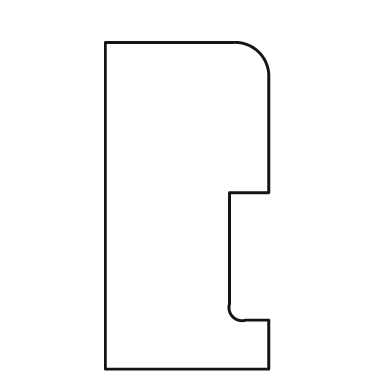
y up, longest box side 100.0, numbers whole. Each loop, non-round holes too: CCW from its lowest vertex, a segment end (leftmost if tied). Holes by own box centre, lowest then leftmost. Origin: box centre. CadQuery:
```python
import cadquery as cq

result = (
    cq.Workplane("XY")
    .moveTo(-25.0, -50.0)
    .lineTo(25.0, -50.0)
    .lineTo(25.0, -35.0)
    .lineTo(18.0, -35.0)
    .threePointArc((14.0, -34.0), (13.0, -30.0))
    .lineTo(13.0, 4.0)
    .lineTo(25.0, 4.0)
    .lineTo(25.0, 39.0)
    .threePointArc((22.0, 47.0), (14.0, 50.0))
    .lineTo(-25.0, 50.0)
    .close()
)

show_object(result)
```